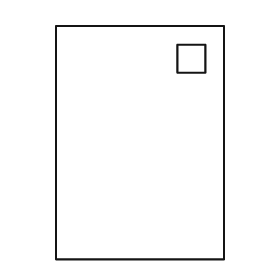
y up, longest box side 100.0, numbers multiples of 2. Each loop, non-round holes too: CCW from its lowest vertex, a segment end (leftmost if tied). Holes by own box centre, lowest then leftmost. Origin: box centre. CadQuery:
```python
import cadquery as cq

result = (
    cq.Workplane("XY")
    .moveTo(-36.0, -50.0)
    .lineTo(36.0, -50.0)
    .lineTo(36.0, 50.0)
    .lineTo(-36.0, 50.0)
    .close()
    .moveTo(16.0, 30.0)
    .lineTo(28.0, 30.0)
    .lineTo(28.0, 42.0)
    .lineTo(16.0, 42.0)
    .close()
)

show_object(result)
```